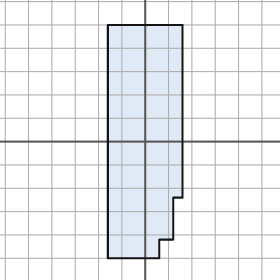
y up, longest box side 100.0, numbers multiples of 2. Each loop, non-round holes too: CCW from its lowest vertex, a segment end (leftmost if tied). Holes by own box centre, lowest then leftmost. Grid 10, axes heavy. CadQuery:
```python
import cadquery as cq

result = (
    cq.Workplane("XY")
    .moveTo(-16.0, -50.0)
    .lineTo(6.0, -50.0)
    .lineTo(6.0, -42.0)
    .lineTo(12.0, -42.0)
    .lineTo(12.0, -24.0)
    .lineTo(16.0, -24.0)
    .lineTo(16.0, 50.0)
    .lineTo(-16.0, 50.0)
    .close()
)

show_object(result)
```